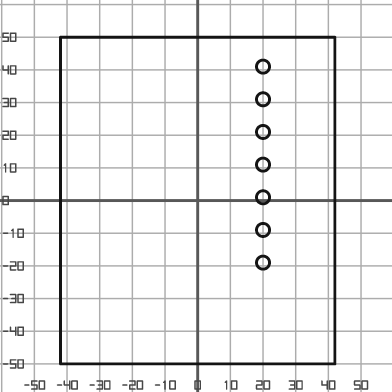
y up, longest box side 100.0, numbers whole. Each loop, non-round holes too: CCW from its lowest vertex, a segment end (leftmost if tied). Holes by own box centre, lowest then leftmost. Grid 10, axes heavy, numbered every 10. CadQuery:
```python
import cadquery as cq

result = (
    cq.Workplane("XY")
    .moveTo(-42.0, -50.0)
    .lineTo(42.0, -50.0)
    .lineTo(42.0, 50.0)
    .lineTo(-42.0, 50.0)
    .close()
    .moveTo(20.0, -19.0)
    .circle(2.0)
    .moveTo(20.0, -9.0)
    .circle(2.0)
    .moveTo(20.0, 1.0)
    .circle(2.0)
    .moveTo(20.0, 11.0)
    .circle(2.0)
    .moveTo(20.0, 21.0)
    .circle(2.0)
    .moveTo(20.0, 31.0)
    .circle(2.0)
    .moveTo(20.0, 41.0)
    .circle(2.0)
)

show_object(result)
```